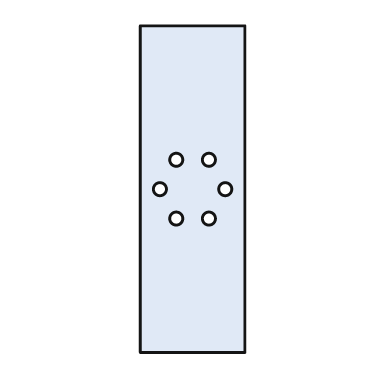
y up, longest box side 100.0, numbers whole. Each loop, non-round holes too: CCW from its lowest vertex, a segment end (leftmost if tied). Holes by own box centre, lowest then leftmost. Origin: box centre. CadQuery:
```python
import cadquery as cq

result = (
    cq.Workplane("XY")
    .moveTo(-16.0, -50.0)
    .lineTo(16.0, -50.0)
    .lineTo(16.0, 50.0)
    .lineTo(-16.0, 50.0)
    .close()
    .moveTo(-5.0, -9.0)
    .circle(2.0)
    .moveTo(5.0, -9.0)
    .circle(2.0)
    .moveTo(-10.0, 0.0)
    .circle(2.0)
    .moveTo(10.0, 0.0)
    .circle(2.0)
    .moveTo(-5.0, 9.0)
    .circle(2.0)
    .moveTo(5.0, 9.0)
    .circle(2.0)
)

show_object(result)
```